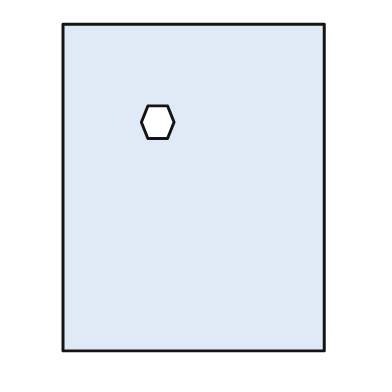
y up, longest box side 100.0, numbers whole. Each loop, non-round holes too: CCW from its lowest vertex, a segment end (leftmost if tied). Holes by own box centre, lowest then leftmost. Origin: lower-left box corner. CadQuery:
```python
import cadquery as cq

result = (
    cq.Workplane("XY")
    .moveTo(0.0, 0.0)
    .lineTo(80.0, 0.0)
    .lineTo(80.0, 100.0)
    .lineTo(0.0, 100.0)
    .close()
    .moveTo(26.0, 65.0)
    .lineTo(32.0, 65.0)
    .lineTo(34.0, 70.0)
    .lineTo(32.0, 75.0)
    .lineTo(26.0, 75.0)
    .lineTo(24.0, 70.0)
    .close()
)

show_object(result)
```